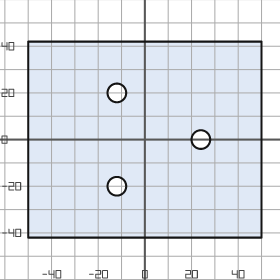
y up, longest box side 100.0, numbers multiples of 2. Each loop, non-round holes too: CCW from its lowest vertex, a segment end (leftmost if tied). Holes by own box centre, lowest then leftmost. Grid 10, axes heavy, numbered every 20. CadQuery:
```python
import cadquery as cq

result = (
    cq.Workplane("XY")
    .moveTo(-50.0, -42.0)
    .lineTo(50.0, -42.0)
    .lineTo(50.0, 42.0)
    .lineTo(-50.0, 42.0)
    .close()
    .moveTo(-12.0, -20.0)
    .circle(4.0)
    .moveTo(24.0, 0.0)
    .circle(4.0)
    .moveTo(-12.0, 20.0)
    .circle(4.0)
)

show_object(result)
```